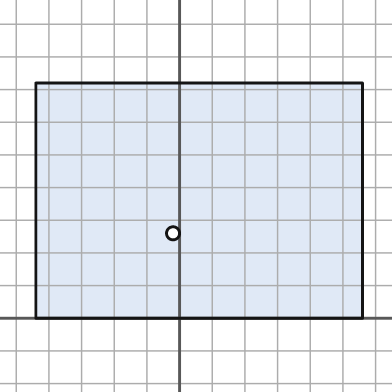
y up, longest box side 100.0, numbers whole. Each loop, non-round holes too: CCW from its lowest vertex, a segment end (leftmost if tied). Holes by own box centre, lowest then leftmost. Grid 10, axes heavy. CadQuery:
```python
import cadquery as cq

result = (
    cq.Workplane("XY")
    .moveTo(-44.0, 0.0)
    .lineTo(56.0, 0.0)
    .lineTo(56.0, 72.0)
    .lineTo(-44.0, 72.0)
    .close()
    .moveTo(-2.0, 26.0)
    .circle(2.0)
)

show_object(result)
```